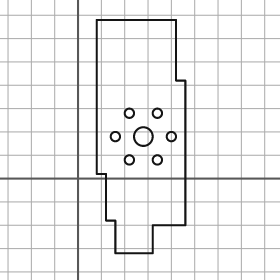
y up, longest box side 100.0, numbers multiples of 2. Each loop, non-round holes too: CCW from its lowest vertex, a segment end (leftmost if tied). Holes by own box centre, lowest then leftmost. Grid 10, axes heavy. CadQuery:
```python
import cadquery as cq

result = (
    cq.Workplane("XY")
    .moveTo(16.0, -32.0)
    .lineTo(32.0, -32.0)
    .lineTo(32.0, -20.0)
    .lineTo(46.0, -20.0)
    .lineTo(46.0, 42.0)
    .lineTo(42.0, 42.0)
    .lineTo(42.0, 68.0)
    .lineTo(8.0, 68.0)
    .lineTo(8.0, 2.0)
    .lineTo(12.0, 2.0)
    .lineTo(12.0, -18.0)
    .lineTo(16.0, -18.0)
    .close()
    .moveTo(22.0, 8.0)
    .circle(2.0)
    .moveTo(34.0, 8.0)
    .circle(2.0)
    .moveTo(16.0, 18.0)
    .circle(2.0)
    .moveTo(28.0, 18.0)
    .circle(4.0)
    .moveTo(40.0, 18.0)
    .circle(2.0)
    .moveTo(22.0, 28.0)
    .circle(2.0)
    .moveTo(34.0, 28.0)
    .circle(2.0)
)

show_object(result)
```